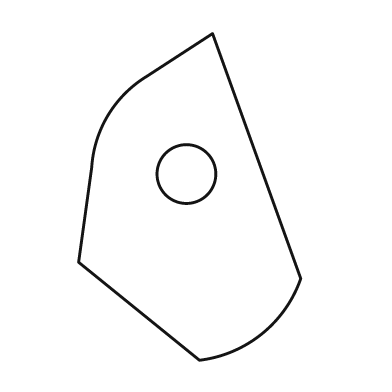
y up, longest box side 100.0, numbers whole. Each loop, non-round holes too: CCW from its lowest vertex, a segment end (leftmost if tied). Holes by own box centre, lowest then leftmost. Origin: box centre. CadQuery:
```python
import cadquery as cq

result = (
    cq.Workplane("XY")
    .moveTo(3.0, -50.0)
    .threePointArc((22.0, -42.0), (34.0, -25.0))
    .lineTo(7.0, 50.0)
    .lineTo(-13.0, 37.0)
    .threePointArc((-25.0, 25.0), (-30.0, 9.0))
    .lineTo(-34.0, -20.0)
    .close()
    .moveTo(-1.0, 7.0)
    .circle(9.0)
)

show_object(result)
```